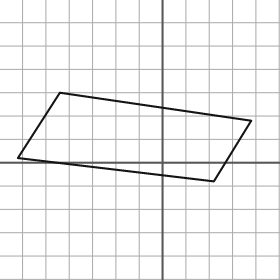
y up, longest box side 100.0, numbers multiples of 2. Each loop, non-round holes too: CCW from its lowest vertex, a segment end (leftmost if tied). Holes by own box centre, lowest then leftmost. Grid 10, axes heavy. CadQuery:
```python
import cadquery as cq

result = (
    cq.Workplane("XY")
    .moveTo(22.0, -8.0)
    .lineTo(38.0, 18.0)
    .lineTo(-44.0, 30.0)
    .lineTo(-62.0, 2.0)
    .close()
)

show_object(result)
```